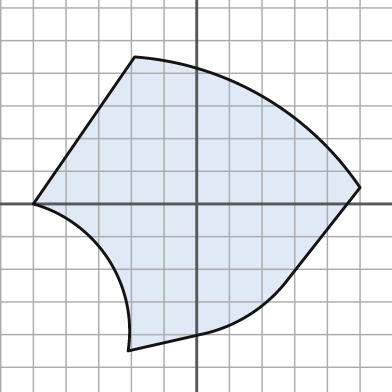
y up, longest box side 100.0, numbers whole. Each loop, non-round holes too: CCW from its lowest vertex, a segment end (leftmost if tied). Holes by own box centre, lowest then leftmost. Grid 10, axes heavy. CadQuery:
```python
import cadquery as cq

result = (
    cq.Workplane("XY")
    .moveTo(-21.0, -45.0)
    .lineTo(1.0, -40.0)
    .threePointArc((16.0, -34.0), (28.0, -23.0))
    .lineTo(50.0, 5.0)
    .threePointArc((20.0, 33.0), (-19.0, 45.0))
    .lineTo(-50.0, 0.0)
    .threePointArc((-27.0, -17.0), (-21.0, -45.0))
    .close()
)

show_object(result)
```